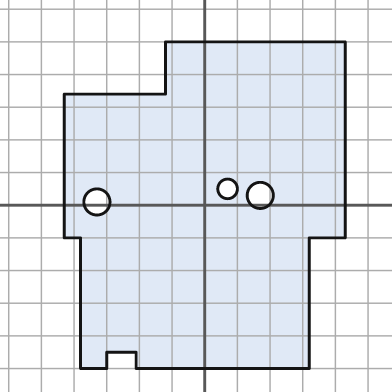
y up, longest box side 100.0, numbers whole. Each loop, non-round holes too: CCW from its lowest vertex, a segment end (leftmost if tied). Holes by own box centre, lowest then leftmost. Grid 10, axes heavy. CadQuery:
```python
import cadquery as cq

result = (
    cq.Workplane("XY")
    .moveTo(-38.0, -50.0)
    .lineTo(-30.0, -50.0)
    .lineTo(-30.0, -45.0)
    .lineTo(-21.0, -45.0)
    .lineTo(-21.0, -50.0)
    .lineTo(32.0, -50.0)
    .lineTo(32.0, -10.0)
    .lineTo(43.0, -10.0)
    .lineTo(43.0, 50.0)
    .lineTo(-12.0, 50.0)
    .lineTo(-12.0, 34.0)
    .lineTo(-43.0, 34.0)
    .lineTo(-43.0, -10.0)
    .lineTo(-38.0, -10.0)
    .close()
    .moveTo(-33.0, 1.0)
    .circle(4.0)
    .moveTo(17.0, 3.0)
    .circle(4.0)
    .moveTo(7.0, 5.0)
    .circle(3.0)
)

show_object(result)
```